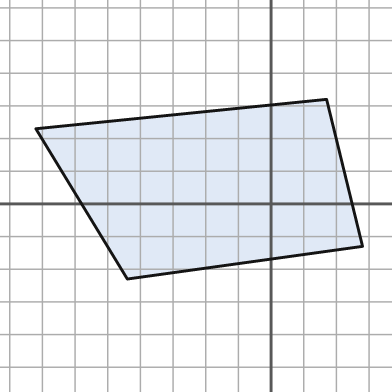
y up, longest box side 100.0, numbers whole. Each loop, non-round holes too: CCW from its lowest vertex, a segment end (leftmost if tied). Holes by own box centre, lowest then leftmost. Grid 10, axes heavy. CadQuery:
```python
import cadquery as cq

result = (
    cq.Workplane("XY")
    .moveTo(-44.0, -23.0)
    .lineTo(28.0, -13.0)
    .lineTo(17.0, 32.0)
    .lineTo(-72.0, 23.0)
    .close()
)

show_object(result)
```